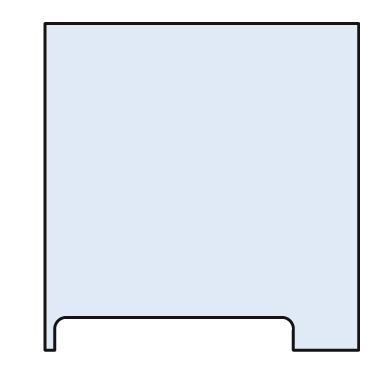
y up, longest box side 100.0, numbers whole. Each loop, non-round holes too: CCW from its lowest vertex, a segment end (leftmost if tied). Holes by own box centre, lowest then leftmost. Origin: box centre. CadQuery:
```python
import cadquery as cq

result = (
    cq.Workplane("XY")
    .moveTo(-48.0, -50.0)
    .lineTo(-45.0, -50.0)
    .lineTo(-45.0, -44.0)
    .threePointArc((-44.0, -41.0), (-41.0, -40.0))
    .lineTo(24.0, -40.0)
    .threePointArc((27.0, -41.0), (28.0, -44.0))
    .lineTo(28.0, -50.0)
    .lineTo(48.0, -50.0)
    .lineTo(48.0, 50.0)
    .lineTo(-48.0, 50.0)
    .close()
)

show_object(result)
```